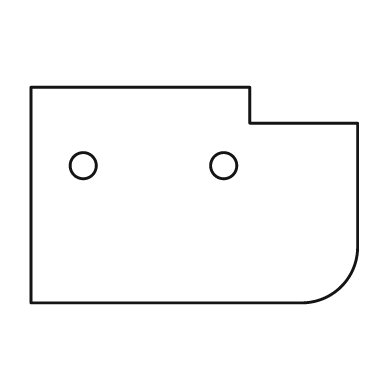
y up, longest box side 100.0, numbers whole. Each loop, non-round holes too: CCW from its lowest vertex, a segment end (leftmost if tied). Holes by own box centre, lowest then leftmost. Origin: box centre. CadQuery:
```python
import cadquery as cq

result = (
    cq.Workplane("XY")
    .moveTo(-50.0, -33.0)
    .lineTo(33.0, -33.0)
    .threePointArc((45.0, -28.0), (50.0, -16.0))
    .lineTo(50.0, 22.0)
    .lineTo(17.0, 22.0)
    .lineTo(17.0, 33.0)
    .lineTo(-50.0, 33.0)
    .close()
    .moveTo(-34.0, 9.0)
    .circle(4.0)
    .moveTo(9.0, 9.0)
    .circle(4.0)
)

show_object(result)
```